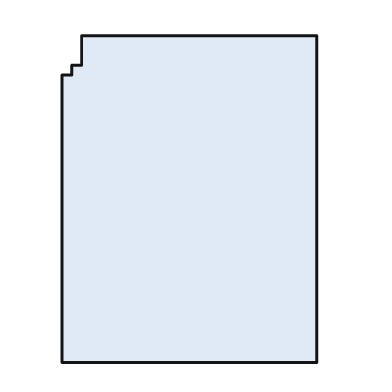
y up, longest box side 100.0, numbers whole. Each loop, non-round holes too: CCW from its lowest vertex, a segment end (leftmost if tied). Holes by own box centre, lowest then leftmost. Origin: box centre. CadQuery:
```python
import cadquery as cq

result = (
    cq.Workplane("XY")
    .moveTo(-39.0, -50.0)
    .lineTo(39.0, -50.0)
    .lineTo(39.0, 50.0)
    .lineTo(-33.0, 50.0)
    .lineTo(-33.0, 41.0)
    .lineTo(-36.0, 41.0)
    .lineTo(-36.0, 38.0)
    .lineTo(-39.0, 38.0)
    .close()
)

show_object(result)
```